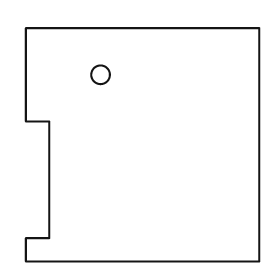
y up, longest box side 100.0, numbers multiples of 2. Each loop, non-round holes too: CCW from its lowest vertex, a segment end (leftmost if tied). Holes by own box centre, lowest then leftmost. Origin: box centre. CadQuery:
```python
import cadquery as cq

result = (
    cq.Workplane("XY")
    .moveTo(-50.0, -50.0)
    .lineTo(50.0, -50.0)
    .lineTo(50.0, 50.0)
    .lineTo(-50.0, 50.0)
    .lineTo(-50.0, 10.0)
    .lineTo(-40.0, 10.0)
    .lineTo(-40.0, -40.0)
    .lineTo(-50.0, -40.0)
    .close()
    .moveTo(-18.0, 30.0)
    .circle(4.0)
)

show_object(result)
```